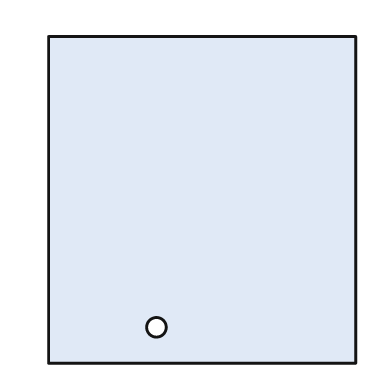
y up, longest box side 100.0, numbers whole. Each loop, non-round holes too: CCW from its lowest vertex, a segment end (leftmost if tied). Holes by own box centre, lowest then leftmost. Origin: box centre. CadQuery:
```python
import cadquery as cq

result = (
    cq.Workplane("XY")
    .moveTo(-47.0, -50.0)
    .lineTo(47.0, -50.0)
    .lineTo(47.0, 50.0)
    .lineTo(-47.0, 50.0)
    .close()
    .moveTo(-14.0, -39.0)
    .circle(3.0)
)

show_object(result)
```